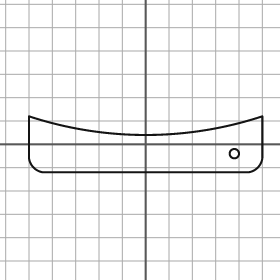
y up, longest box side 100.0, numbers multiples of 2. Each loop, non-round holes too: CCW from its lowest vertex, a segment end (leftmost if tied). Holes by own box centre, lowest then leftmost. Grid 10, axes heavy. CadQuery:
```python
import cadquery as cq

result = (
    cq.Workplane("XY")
    .moveTo(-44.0, -12.0)
    .lineTo(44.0, -12.0)
    .threePointArc((48.0, -10.0), (50.0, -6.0))
    .lineTo(50.0, 12.0)
    .threePointArc((0.0, 4.0), (-50.0, 12.0))
    .lineTo(-50.0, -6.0)
    .threePointArc((-48.0, -10.0), (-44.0, -12.0))
    .close()
    .moveTo(38.0, -4.0)
    .circle(2.0)
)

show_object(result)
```